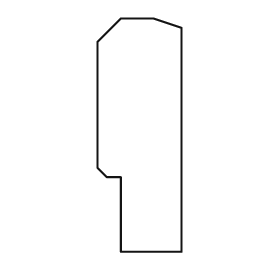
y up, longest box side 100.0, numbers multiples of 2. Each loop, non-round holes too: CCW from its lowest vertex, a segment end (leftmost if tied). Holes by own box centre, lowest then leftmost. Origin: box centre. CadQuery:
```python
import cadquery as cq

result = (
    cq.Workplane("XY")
    .moveTo(-8.0, -50.0)
    .lineTo(18.0, -50.0)
    .lineTo(18.0, 46.0)
    .lineTo(6.0, 50.0)
    .lineTo(-8.0, 50.0)
    .lineTo(-18.0, 40.0)
    .lineTo(-18.0, -14.0)
    .lineTo(-14.0, -18.0)
    .lineTo(-8.0, -18.0)
    .close()
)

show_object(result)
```